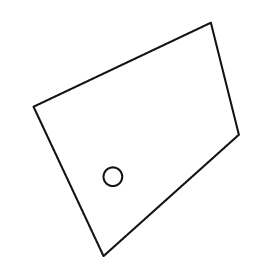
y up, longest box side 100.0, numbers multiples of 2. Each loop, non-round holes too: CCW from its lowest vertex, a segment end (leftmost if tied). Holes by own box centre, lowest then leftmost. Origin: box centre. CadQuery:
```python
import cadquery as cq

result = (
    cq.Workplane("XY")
    .moveTo(-14.0, -50.0)
    .lineTo(44.0, 2.0)
    .lineTo(32.0, 50.0)
    .lineTo(-44.0, 14.0)
    .close()
    .moveTo(-10.0, -16.0)
    .circle(4.0)
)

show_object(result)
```